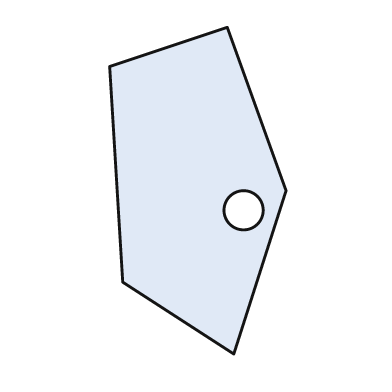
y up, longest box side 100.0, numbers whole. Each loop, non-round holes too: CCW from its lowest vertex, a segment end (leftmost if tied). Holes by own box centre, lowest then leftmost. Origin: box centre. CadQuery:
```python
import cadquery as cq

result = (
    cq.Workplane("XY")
    .moveTo(11.0, -50.0)
    .lineTo(27.0, 0.0)
    .lineTo(9.0, 50.0)
    .lineTo(-27.0, 38.0)
    .lineTo(-23.0, -28.0)
    .close()
    .moveTo(14.0, -6.0)
    .circle(6.0)
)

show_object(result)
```